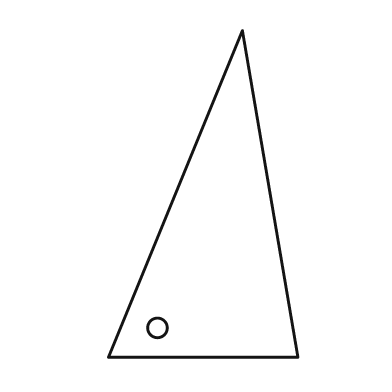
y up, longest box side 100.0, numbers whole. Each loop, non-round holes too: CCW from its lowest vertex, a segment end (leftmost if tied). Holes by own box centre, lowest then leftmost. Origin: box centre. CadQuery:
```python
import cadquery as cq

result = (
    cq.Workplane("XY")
    .moveTo(-29.0, -50.0)
    .lineTo(29.0, -50.0)
    .lineTo(12.0, 50.0)
    .close()
    .moveTo(-14.0, -41.0)
    .circle(3.0)
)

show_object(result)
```